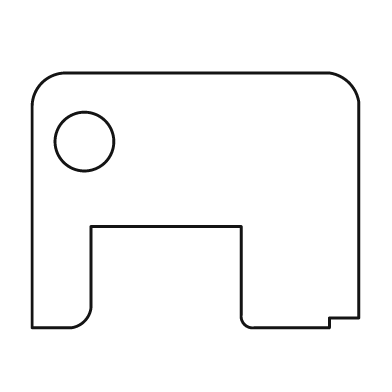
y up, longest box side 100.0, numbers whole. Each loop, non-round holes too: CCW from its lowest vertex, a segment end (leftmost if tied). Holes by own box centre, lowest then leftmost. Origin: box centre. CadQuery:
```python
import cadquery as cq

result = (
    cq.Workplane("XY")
    .moveTo(-50.0, -39.0)
    .lineTo(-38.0, -39.0)
    .threePointArc((-34.0, -37.0), (-32.0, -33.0))
    .lineTo(-32.0, -8.0)
    .lineTo(14.0, -8.0)
    .lineTo(14.0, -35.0)
    .threePointArc((15.0, -38.0), (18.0, -39.0))
    .lineTo(41.0, -39.0)
    .lineTo(41.0, -36.0)
    .lineTo(50.0, -36.0)
    .lineTo(50.0, 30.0)
    .threePointArc((47.0, 36.0), (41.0, 39.0))
    .lineTo(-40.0, 39.0)
    .threePointArc((-47.0, 36.0), (-50.0, 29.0))
    .close()
    .moveTo(-34.0, 18.0)
    .circle(9.0)
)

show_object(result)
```